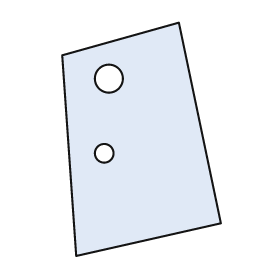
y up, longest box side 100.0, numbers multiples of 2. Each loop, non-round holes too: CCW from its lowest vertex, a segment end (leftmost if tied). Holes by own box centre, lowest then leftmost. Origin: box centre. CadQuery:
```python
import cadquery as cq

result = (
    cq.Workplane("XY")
    .moveTo(-28.0, -50.0)
    .lineTo(34.0, -36.0)
    .lineTo(16.0, 50.0)
    .lineTo(-34.0, 36.0)
    .close()
    .moveTo(-16.0, -6.0)
    .circle(4.0)
    .moveTo(-14.0, 26.0)
    .circle(6.0)
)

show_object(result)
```